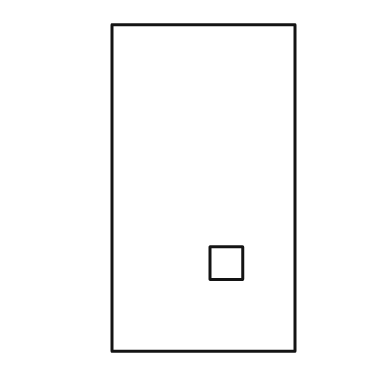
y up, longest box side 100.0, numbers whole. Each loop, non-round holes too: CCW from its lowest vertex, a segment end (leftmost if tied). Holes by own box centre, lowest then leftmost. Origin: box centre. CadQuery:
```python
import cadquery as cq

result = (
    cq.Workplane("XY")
    .moveTo(-28.0, -50.0)
    .lineTo(28.0, -50.0)
    .lineTo(28.0, 50.0)
    .lineTo(-28.0, 50.0)
    .close()
    .moveTo(2.0, -28.0)
    .lineTo(12.0, -28.0)
    .lineTo(12.0, -18.0)
    .lineTo(2.0, -18.0)
    .close()
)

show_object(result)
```